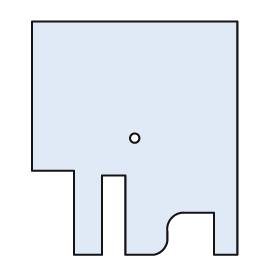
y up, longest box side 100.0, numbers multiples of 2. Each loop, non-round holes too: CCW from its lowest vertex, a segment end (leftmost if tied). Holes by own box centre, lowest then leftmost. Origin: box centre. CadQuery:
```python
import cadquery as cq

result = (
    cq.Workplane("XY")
    .moveTo(-26.0, -50.0)
    .lineTo(-14.0, -50.0)
    .lineTo(-14.0, -16.0)
    .lineTo(-4.0, -16.0)
    .lineTo(-4.0, -50.0)
    .lineTo(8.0, -50.0)
    .threePointArc((12.0, -48.0), (14.0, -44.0))
    .lineTo(14.0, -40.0)
    .threePointArc((16.0, -34.0), (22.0, -32.0))
    .lineTo(34.0, -32.0)
    .lineTo(34.0, -50.0)
    .lineTo(44.0, -50.0)
    .lineTo(44.0, 50.0)
    .lineTo(-44.0, 50.0)
    .lineTo(-44.0, -14.0)
    .lineTo(-26.0, -14.0)
    .close()
    .moveTo(0.0, 0.0)
    .circle(2.0)
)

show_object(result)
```